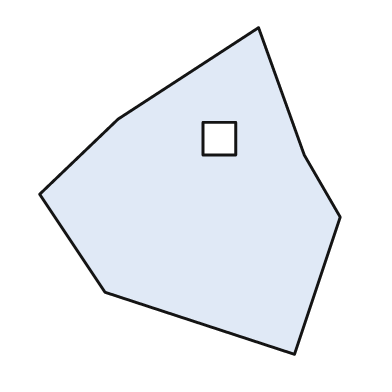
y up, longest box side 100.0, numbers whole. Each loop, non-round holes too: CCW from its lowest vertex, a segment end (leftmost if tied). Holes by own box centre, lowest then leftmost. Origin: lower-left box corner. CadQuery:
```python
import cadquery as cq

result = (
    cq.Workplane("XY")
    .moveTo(78.0, 0.0)
    .lineTo(92.0, 42.0)
    .lineTo(81.0, 61.0)
    .lineTo(67.0, 100.0)
    .lineTo(24.0, 72.0)
    .lineTo(0.0, 49.0)
    .lineTo(20.0, 19.0)
    .close()
    .moveTo(50.0, 61.0)
    .lineTo(60.0, 61.0)
    .lineTo(60.0, 71.0)
    .lineTo(50.0, 71.0)
    .close()
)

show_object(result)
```